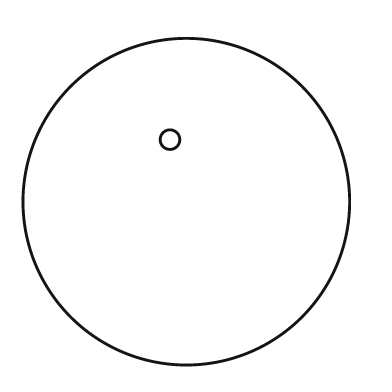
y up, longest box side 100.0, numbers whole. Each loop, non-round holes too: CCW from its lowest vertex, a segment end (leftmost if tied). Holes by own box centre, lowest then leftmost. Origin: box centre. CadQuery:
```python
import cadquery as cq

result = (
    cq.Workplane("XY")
    .moveTo(0.0, 0.0)
    .circle(50.0)
    .moveTo(-5.0, 19.0)
    .circle(3.0)
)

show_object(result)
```